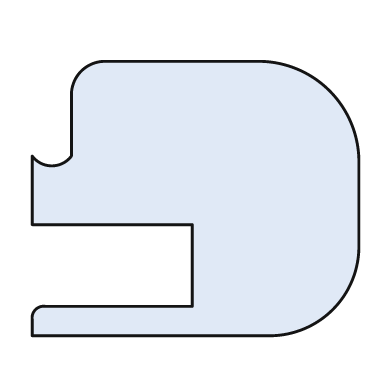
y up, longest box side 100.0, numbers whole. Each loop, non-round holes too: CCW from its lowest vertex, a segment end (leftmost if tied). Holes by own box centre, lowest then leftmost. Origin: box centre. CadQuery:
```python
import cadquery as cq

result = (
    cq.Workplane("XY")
    .moveTo(-50.0, -42.0)
    .lineTo(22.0, -42.0)
    .threePointArc((42.0, -34.0), (50.0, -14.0))
    .lineTo(50.0, 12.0)
    .threePointArc((41.0, 33.0), (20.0, 42.0))
    .lineTo(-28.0, 42.0)
    .threePointArc((-35.0, 39.0), (-38.0, 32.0))
    .lineTo(-38.0, 13.0)
    .threePointArc((-44.0, 10.0), (-50.0, 13.0))
    .lineTo(-50.0, -8.0)
    .lineTo(-1.0, -8.0)
    .lineTo(-1.0, -33.0)
    .lineTo(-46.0, -33.0)
    .threePointArc((-49.0, -34.0), (-50.0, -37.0))
    .close()
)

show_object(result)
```